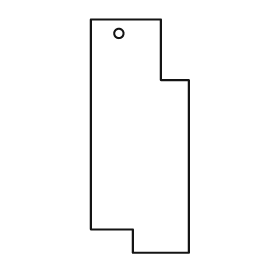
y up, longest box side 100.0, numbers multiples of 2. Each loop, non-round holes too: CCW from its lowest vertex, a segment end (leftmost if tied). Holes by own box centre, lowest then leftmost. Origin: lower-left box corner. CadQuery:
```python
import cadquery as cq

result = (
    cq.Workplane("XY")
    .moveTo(18.0, 0.0)
    .lineTo(42.0, 0.0)
    .lineTo(42.0, 74.0)
    .lineTo(30.0, 74.0)
    .lineTo(30.0, 100.0)
    .lineTo(0.0, 100.0)
    .lineTo(0.0, 10.0)
    .lineTo(18.0, 10.0)
    .close()
    .moveTo(12.0, 94.0)
    .circle(2.0)
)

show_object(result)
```